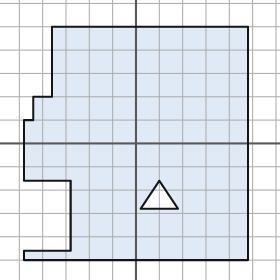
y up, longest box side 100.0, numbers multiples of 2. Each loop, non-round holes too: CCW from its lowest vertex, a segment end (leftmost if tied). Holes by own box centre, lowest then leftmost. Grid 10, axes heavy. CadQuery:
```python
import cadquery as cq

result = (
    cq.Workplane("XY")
    .moveTo(-48.0, -50.0)
    .lineTo(48.0, -50.0)
    .lineTo(48.0, 50.0)
    .lineTo(-36.0, 50.0)
    .lineTo(-36.0, 20.0)
    .lineTo(-44.0, 20.0)
    .lineTo(-44.0, 10.0)
    .lineTo(-48.0, 10.0)
    .lineTo(-48.0, -16.0)
    .lineTo(-28.0, -16.0)
    .lineTo(-28.0, -46.0)
    .lineTo(-48.0, -46.0)
    .close()
    .moveTo(2.0, -28.0)
    .lineTo(18.0, -28.0)
    .lineTo(10.0, -16.0)
    .close()
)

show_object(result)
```